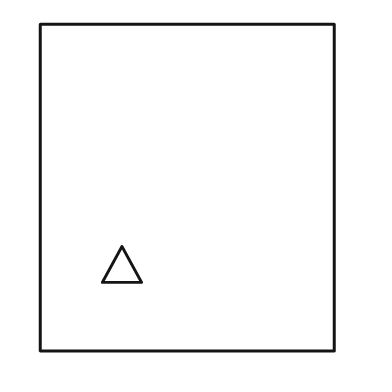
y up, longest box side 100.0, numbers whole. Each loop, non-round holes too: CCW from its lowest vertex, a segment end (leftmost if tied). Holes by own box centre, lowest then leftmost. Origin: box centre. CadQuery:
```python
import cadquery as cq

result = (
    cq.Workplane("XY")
    .moveTo(-45.0, -50.0)
    .lineTo(45.0, -50.0)
    .lineTo(45.0, 50.0)
    .lineTo(-45.0, 50.0)
    .close()
    .moveTo(-26.0, -29.0)
    .lineTo(-14.0, -29.0)
    .lineTo(-20.0, -18.0)
    .close()
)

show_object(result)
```